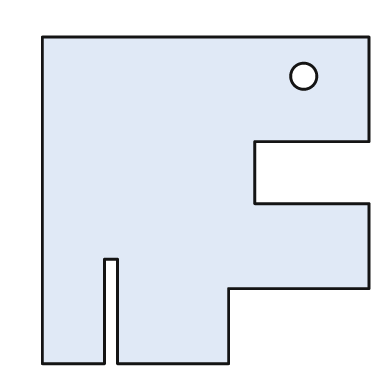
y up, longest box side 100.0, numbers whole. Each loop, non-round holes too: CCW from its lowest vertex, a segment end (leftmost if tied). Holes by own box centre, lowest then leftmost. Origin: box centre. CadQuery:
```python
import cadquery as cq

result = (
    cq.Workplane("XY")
    .moveTo(-50.0, -50.0)
    .lineTo(-31.0, -50.0)
    .lineTo(-31.0, -18.0)
    .lineTo(-27.0, -18.0)
    .lineTo(-27.0, -50.0)
    .lineTo(7.0, -50.0)
    .lineTo(7.0, -27.0)
    .lineTo(50.0, -27.0)
    .lineTo(50.0, -1.0)
    .lineTo(15.0, -1.0)
    .lineTo(15.0, 18.0)
    .lineTo(50.0, 18.0)
    .lineTo(50.0, 50.0)
    .lineTo(-50.0, 50.0)
    .close()
    .moveTo(30.0, 38.0)
    .circle(4.0)
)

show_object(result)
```